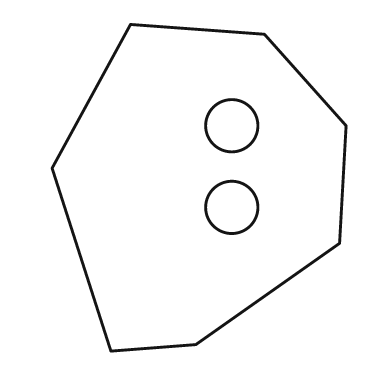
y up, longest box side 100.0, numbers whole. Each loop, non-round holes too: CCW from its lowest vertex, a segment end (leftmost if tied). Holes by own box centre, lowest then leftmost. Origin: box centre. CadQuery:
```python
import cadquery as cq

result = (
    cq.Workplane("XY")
    .moveTo(-27.0, -50.0)
    .lineTo(-1.0, -48.0)
    .lineTo(43.0, -17.0)
    .lineTo(45.0, 19.0)
    .lineTo(20.0, 47.0)
    .lineTo(-21.0, 50.0)
    .lineTo(-45.0, 6.0)
    .close()
    .moveTo(10.0, -6.0)
    .circle(8.0)
    .moveTo(10.0, 19.0)
    .circle(8.0)
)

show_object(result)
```